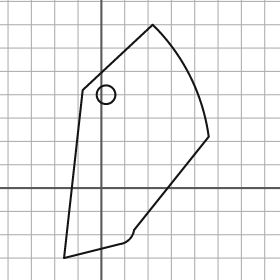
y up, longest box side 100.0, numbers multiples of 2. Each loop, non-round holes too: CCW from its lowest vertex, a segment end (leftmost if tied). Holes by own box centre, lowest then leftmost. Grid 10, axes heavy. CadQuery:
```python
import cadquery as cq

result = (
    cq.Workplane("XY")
    .moveTo(-16.0, -30.0)
    .lineTo(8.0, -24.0)
    .threePointArc((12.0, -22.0), (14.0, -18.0))
    .lineTo(46.0, 22.0)
    .threePointArc((38.0, 48.0), (22.0, 70.0))
    .lineTo(-8.0, 42.0)
    .close()
    .moveTo(2.0, 40.0)
    .circle(4.0)
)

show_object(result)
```